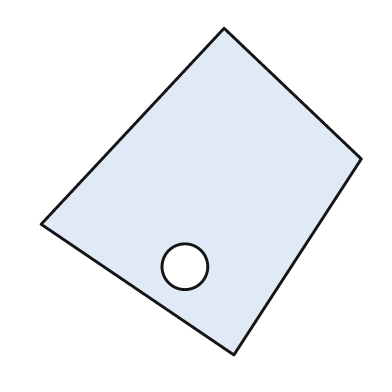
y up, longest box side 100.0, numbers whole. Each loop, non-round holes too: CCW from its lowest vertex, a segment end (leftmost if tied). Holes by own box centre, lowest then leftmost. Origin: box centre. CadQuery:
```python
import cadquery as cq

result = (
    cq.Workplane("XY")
    .moveTo(10.0, -50.0)
    .lineTo(49.0, 10.0)
    .lineTo(7.0, 50.0)
    .lineTo(-49.0, -10.0)
    .close()
    .moveTo(-5.0, -23.0)
    .circle(7.0)
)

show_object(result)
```